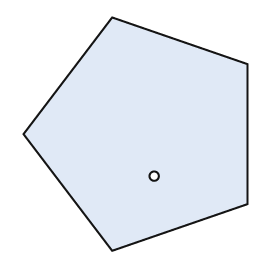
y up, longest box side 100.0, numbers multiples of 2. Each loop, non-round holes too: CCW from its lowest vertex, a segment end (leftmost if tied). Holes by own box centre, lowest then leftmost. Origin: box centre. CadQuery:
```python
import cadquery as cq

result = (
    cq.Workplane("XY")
    .moveTo(-10.0, -50.0)
    .lineTo(48.0, -30.0)
    .lineTo(48.0, 30.0)
    .lineTo(-10.0, 50.0)
    .lineTo(-48.0, 0.0)
    .close()
    .moveTo(8.0, -18.0)
    .circle(2.0)
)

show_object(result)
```